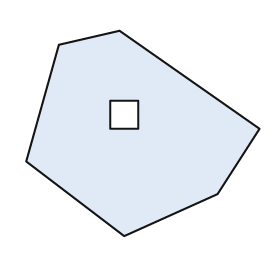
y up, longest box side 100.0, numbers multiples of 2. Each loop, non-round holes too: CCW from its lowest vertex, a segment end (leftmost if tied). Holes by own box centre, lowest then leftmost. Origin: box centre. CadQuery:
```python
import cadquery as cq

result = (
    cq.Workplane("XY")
    .moveTo(-8.0, -44.0)
    .lineTo(32.0, -26.0)
    .lineTo(50.0, 2.0)
    .lineTo(-10.0, 44.0)
    .lineTo(-36.0, 38.0)
    .lineTo(-50.0, -12.0)
    .close()
    .moveTo(-14.0, 2.0)
    .lineTo(-2.0, 2.0)
    .lineTo(-2.0, 14.0)
    .lineTo(-14.0, 14.0)
    .close()
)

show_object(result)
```